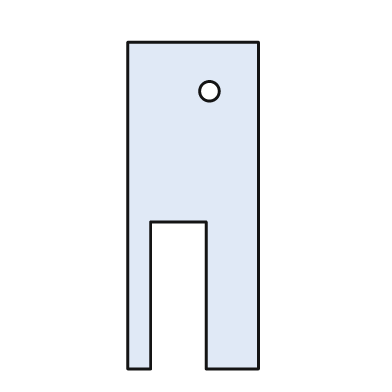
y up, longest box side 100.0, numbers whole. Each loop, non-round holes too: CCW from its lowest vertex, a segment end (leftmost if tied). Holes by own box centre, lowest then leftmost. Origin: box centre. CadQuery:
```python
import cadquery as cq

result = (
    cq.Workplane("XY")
    .moveTo(-20.0, -50.0)
    .lineTo(-13.0, -50.0)
    .lineTo(-13.0, -5.0)
    .lineTo(4.0, -5.0)
    .lineTo(4.0, -50.0)
    .lineTo(20.0, -50.0)
    .lineTo(20.0, 50.0)
    .lineTo(-20.0, 50.0)
    .close()
    .moveTo(5.0, 35.0)
    .circle(3.0)
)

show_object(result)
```